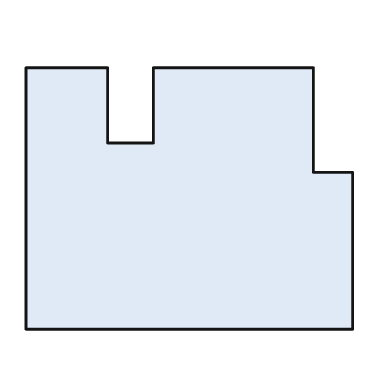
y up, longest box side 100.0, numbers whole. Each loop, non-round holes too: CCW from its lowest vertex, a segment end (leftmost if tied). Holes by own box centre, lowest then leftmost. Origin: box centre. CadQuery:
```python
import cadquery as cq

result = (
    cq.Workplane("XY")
    .moveTo(-50.0, -40.0)
    .lineTo(50.0, -40.0)
    .lineTo(50.0, 8.0)
    .lineTo(38.0, 8.0)
    .lineTo(38.0, 40.0)
    .lineTo(-11.0, 40.0)
    .lineTo(-11.0, 17.0)
    .lineTo(-25.0, 17.0)
    .lineTo(-25.0, 40.0)
    .lineTo(-50.0, 40.0)
    .close()
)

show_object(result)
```